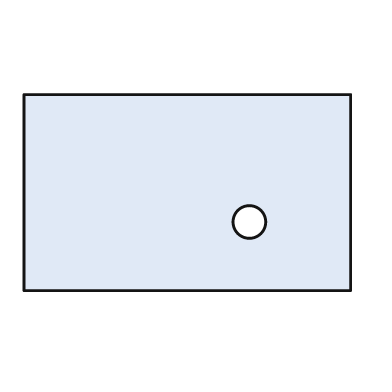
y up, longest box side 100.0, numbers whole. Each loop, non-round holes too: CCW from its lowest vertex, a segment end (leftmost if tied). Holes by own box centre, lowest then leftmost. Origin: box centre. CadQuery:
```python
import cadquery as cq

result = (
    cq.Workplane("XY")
    .moveTo(-50.0, -30.0)
    .lineTo(50.0, -30.0)
    .lineTo(50.0, 30.0)
    .lineTo(-50.0, 30.0)
    .close()
    .moveTo(19.0, -9.0)
    .circle(5.0)
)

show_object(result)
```